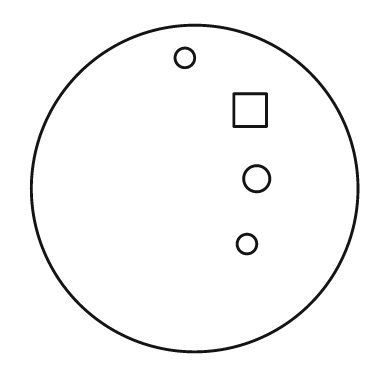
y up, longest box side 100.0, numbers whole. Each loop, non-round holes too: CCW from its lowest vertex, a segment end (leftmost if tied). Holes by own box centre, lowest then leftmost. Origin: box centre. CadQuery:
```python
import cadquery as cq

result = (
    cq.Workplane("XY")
    .moveTo(0.0, 0.0)
    .circle(50.0)
    .moveTo(16.0, -17.0)
    .circle(3.0)
    .moveTo(19.0, 3.0)
    .circle(4.0)
    .moveTo(12.0, 19.0)
    .lineTo(22.0, 19.0)
    .lineTo(22.0, 29.0)
    .lineTo(12.0, 29.0)
    .close()
    .moveTo(-3.0, 40.0)
    .circle(3.0)
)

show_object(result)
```